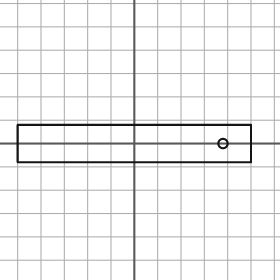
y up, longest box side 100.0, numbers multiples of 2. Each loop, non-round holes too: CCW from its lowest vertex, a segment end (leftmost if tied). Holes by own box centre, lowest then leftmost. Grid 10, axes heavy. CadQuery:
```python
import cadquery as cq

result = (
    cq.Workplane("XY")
    .moveTo(-50.0, -8.0)
    .lineTo(50.0, -8.0)
    .lineTo(50.0, 8.0)
    .lineTo(-50.0, 8.0)
    .close()
    .moveTo(38.0, 0.0)
    .circle(2.0)
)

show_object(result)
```